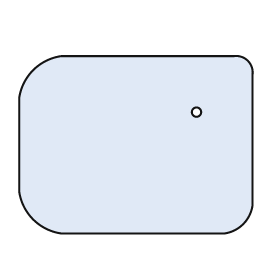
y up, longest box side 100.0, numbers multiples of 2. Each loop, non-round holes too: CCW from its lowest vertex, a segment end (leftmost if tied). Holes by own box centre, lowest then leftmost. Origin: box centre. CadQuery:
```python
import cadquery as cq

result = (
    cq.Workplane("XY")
    .moveTo(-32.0, -38.0)
    .lineTo(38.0, -38.0)
    .threePointArc((46.0, -34.0), (50.0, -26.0))
    .lineTo(50.0, 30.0)
    .threePointArc((48.0, 36.0), (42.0, 38.0))
    .lineTo(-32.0, 38.0)
    .threePointArc((-44.0, 32.0), (-50.0, 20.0))
    .lineTo(-50.0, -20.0)
    .threePointArc((-44.0, -32.0), (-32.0, -38.0))
    .close()
    .moveTo(26.0, 14.0)
    .circle(2.0)
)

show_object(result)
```